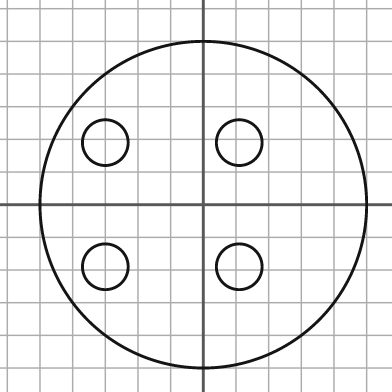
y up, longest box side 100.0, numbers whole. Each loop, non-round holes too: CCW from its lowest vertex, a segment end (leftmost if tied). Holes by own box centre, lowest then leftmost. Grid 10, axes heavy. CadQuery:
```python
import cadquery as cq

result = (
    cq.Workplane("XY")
    .moveTo(0.0, 0.0)
    .circle(50.0)
    .moveTo(-30.0, -19.0)
    .circle(7.0)
    .moveTo(11.0, -19.0)
    .circle(7.0)
    .moveTo(-30.0, 19.0)
    .circle(7.0)
    .moveTo(11.0, 19.0)
    .circle(7.0)
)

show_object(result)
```